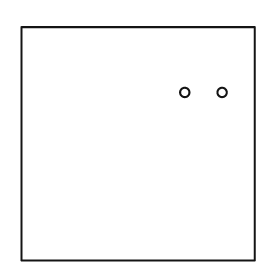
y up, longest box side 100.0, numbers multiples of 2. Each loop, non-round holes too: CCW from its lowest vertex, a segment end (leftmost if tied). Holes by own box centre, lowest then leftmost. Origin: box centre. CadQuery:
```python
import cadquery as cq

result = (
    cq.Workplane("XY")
    .moveTo(-50.0, -50.0)
    .lineTo(50.0, -50.0)
    .lineTo(50.0, 50.0)
    .lineTo(-50.0, 50.0)
    .close()
    .moveTo(20.0, 22.0)
    .circle(2.0)
    .moveTo(36.0, 22.0)
    .circle(2.0)
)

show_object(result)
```